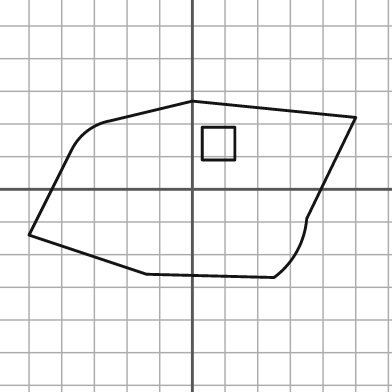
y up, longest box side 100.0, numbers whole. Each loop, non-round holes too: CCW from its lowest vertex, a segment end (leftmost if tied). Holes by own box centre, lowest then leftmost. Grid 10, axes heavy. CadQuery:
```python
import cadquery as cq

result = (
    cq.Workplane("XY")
    .moveTo(25.0, -27.0)
    .threePointArc((32.0, -19.0), (35.0, -9.0))
    .lineTo(50.0, 22.0)
    .lineTo(0.0, 27.0)
    .lineTo(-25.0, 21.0)
    .threePointArc((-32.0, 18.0), (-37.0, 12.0))
    .lineTo(-50.0, -14.0)
    .lineTo(-14.0, -26.0)
    .close()
    .moveTo(3.0, 9.0)
    .lineTo(13.0, 9.0)
    .lineTo(13.0, 19.0)
    .lineTo(3.0, 19.0)
    .close()
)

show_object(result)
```